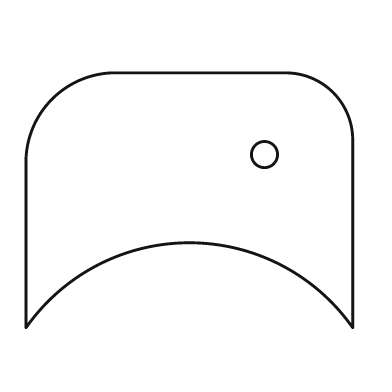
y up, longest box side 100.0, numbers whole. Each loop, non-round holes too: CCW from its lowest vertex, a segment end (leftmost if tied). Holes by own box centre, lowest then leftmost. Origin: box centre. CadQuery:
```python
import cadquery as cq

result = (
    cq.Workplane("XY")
    .moveTo(-50.0, -39.0)
    .threePointArc((0.0, -13.0), (50.0, -39.0))
    .lineTo(50.0, 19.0)
    .threePointArc((44.0, 33.0), (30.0, 39.0))
    .lineTo(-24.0, 39.0)
    .threePointArc((-42.0, 31.0), (-50.0, 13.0))
    .close()
    .moveTo(23.0, 14.0)
    .circle(4.0)
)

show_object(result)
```